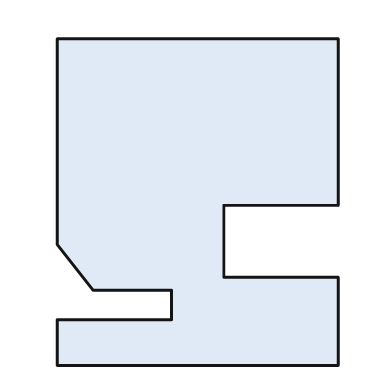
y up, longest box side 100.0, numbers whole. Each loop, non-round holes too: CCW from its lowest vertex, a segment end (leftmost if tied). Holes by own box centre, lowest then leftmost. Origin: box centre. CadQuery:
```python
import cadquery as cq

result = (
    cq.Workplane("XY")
    .moveTo(-43.0, -50.0)
    .lineTo(43.0, -50.0)
    .lineTo(43.0, -23.0)
    .lineTo(8.0, -23.0)
    .lineTo(8.0, -1.0)
    .lineTo(43.0, -1.0)
    .lineTo(43.0, 50.0)
    .lineTo(-43.0, 50.0)
    .lineTo(-43.0, -13.0)
    .lineTo(-32.0, -27.0)
    .lineTo(-8.0, -27.0)
    .lineTo(-8.0, -36.0)
    .lineTo(-43.0, -36.0)
    .close()
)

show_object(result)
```